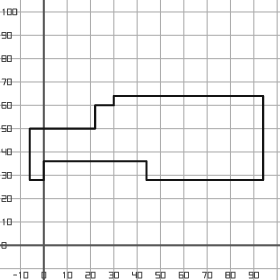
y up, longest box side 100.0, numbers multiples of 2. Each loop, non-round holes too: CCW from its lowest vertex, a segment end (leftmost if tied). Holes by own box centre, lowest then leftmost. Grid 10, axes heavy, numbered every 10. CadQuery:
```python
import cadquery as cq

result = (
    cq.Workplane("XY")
    .moveTo(-6.0, 28.0)
    .lineTo(0.0, 28.0)
    .lineTo(0.0, 36.0)
    .lineTo(44.0, 36.0)
    .lineTo(44.0, 28.0)
    .lineTo(94.0, 28.0)
    .lineTo(94.0, 64.0)
    .lineTo(30.0, 64.0)
    .lineTo(30.0, 60.0)
    .lineTo(22.0, 60.0)
    .lineTo(22.0, 50.0)
    .lineTo(-6.0, 50.0)
    .close()
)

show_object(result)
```